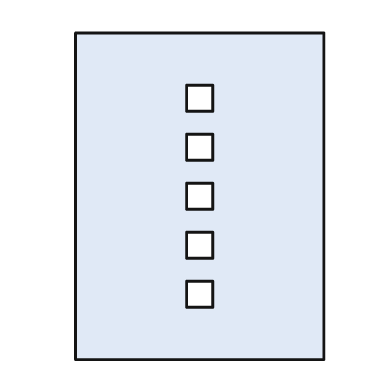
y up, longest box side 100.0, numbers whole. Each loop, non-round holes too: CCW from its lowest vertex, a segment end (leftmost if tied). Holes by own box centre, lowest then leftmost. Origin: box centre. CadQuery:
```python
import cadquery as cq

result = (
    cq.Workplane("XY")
    .moveTo(-38.0, -50.0)
    .lineTo(38.0, -50.0)
    .lineTo(38.0, 50.0)
    .lineTo(-38.0, 50.0)
    .close()
    .moveTo(-4.0, -34.0)
    .lineTo(4.0, -34.0)
    .lineTo(4.0, -26.0)
    .lineTo(-4.0, -26.0)
    .close()
    .moveTo(-4.0, -19.0)
    .lineTo(4.0, -19.0)
    .lineTo(4.0, -11.0)
    .lineTo(-4.0, -11.0)
    .close()
    .moveTo(-4.0, -4.0)
    .lineTo(4.0, -4.0)
    .lineTo(4.0, 4.0)
    .lineTo(-4.0, 4.0)
    .close()
    .moveTo(-4.0, 11.0)
    .lineTo(4.0, 11.0)
    .lineTo(4.0, 19.0)
    .lineTo(-4.0, 19.0)
    .close()
    .moveTo(-4.0, 26.0)
    .lineTo(4.0, 26.0)
    .lineTo(4.0, 34.0)
    .lineTo(-4.0, 34.0)
    .close()
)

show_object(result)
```